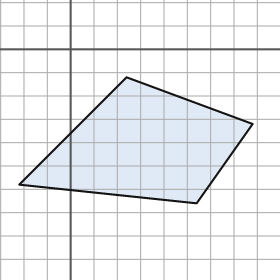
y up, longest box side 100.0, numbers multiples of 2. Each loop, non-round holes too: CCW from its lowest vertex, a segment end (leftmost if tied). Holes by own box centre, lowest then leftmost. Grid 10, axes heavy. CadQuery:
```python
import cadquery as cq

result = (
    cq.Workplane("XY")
    .moveTo(54.0, -66.0)
    .lineTo(78.0, -32.0)
    .lineTo(24.0, -12.0)
    .lineTo(-22.0, -58.0)
    .close()
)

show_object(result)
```